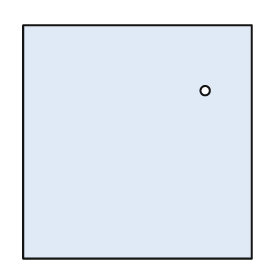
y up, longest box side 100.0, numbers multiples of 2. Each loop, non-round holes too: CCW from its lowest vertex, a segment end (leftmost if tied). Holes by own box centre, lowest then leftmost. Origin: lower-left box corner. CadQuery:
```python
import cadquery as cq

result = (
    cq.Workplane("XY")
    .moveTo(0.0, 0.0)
    .lineTo(98.0, 0.0)
    .lineTo(98.0, 100.0)
    .lineTo(0.0, 100.0)
    .close()
    .moveTo(78.0, 72.0)
    .circle(2.0)
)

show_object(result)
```